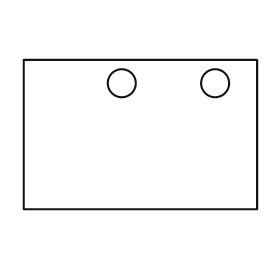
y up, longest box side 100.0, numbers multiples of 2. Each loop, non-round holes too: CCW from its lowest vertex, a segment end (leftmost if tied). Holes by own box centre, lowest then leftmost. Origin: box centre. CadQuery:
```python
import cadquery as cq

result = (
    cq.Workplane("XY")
    .moveTo(-50.0, -32.0)
    .lineTo(50.0, -32.0)
    .lineTo(50.0, 32.0)
    .lineTo(-50.0, 32.0)
    .close()
    .moveTo(-8.0, 22.0)
    .circle(6.0)
    .moveTo(32.0, 22.0)
    .circle(6.0)
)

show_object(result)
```